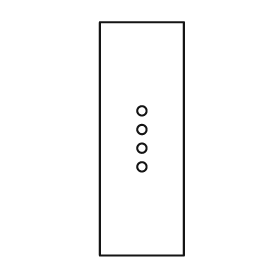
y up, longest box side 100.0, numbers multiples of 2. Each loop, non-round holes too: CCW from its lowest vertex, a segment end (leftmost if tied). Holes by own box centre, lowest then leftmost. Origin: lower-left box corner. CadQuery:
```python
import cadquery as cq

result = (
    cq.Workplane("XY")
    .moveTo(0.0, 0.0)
    .lineTo(36.0, 0.0)
    .lineTo(36.0, 100.0)
    .lineTo(0.0, 100.0)
    .close()
    .moveTo(18.0, 38.0)
    .circle(2.0)
    .moveTo(18.0, 46.0)
    .circle(2.0)
    .moveTo(18.0, 54.0)
    .circle(2.0)
    .moveTo(18.0, 62.0)
    .circle(2.0)
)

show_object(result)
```